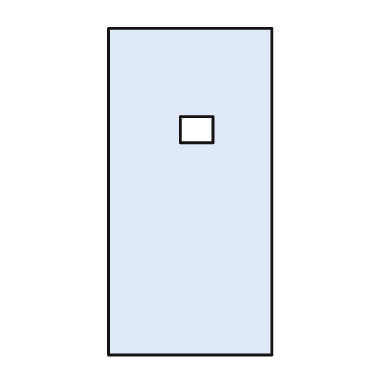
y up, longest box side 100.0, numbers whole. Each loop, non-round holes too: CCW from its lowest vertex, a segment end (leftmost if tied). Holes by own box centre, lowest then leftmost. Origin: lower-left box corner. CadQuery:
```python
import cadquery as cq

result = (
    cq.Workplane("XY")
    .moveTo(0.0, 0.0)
    .lineTo(50.0, 0.0)
    .lineTo(50.0, 100.0)
    .lineTo(0.0, 100.0)
    .close()
    .moveTo(22.0, 65.0)
    .lineTo(32.0, 65.0)
    .lineTo(32.0, 73.0)
    .lineTo(22.0, 73.0)
    .close()
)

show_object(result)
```